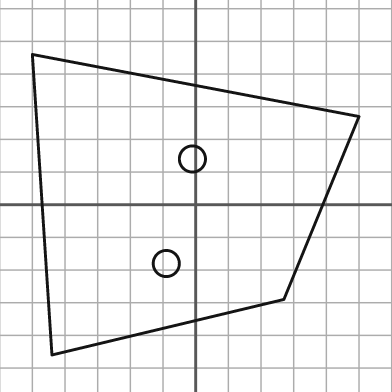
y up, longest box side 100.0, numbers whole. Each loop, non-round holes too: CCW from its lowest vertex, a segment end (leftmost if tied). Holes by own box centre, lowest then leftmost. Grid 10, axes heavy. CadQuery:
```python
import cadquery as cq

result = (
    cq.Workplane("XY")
    .moveTo(-44.0, -46.0)
    .lineTo(27.0, -29.0)
    .lineTo(50.0, 27.0)
    .lineTo(-50.0, 46.0)
    .close()
    .moveTo(-9.0, -18.0)
    .circle(4.0)
    .moveTo(-1.0, 14.0)
    .circle(4.0)
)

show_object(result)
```